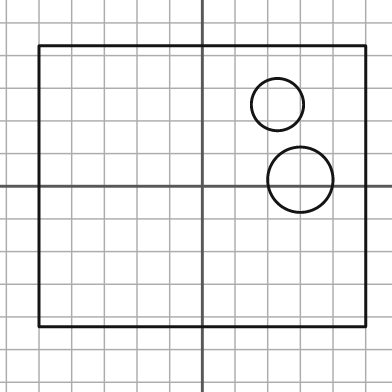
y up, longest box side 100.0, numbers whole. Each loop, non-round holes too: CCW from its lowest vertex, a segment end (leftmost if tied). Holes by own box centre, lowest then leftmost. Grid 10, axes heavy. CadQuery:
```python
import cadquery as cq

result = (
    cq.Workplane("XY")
    .moveTo(-50.0, -43.0)
    .lineTo(50.0, -43.0)
    .lineTo(50.0, 43.0)
    .lineTo(-50.0, 43.0)
    .close()
    .moveTo(30.0, 2.0)
    .circle(10.0)
    .moveTo(23.0, 25.0)
    .circle(8.0)
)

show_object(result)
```